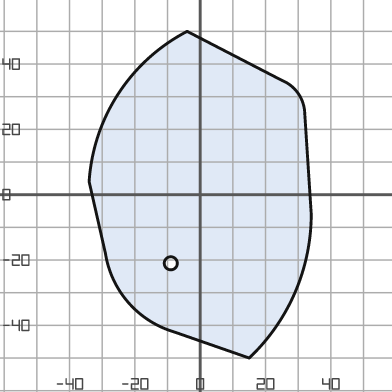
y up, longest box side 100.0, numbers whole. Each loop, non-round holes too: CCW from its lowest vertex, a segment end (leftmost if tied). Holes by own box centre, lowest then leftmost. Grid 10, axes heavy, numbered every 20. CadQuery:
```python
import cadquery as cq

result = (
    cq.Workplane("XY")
    .moveTo(15.0, -50.0)
    .threePointArc((29.0, -30.0), (34.0, -6.0))
    .lineTo(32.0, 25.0)
    .threePointArc((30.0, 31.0), (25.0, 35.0))
    .lineTo(-4.0, 50.0)
    .threePointArc((-25.0, 31.0), (-34.0, 4.0))
    .lineTo(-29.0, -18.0)
    .threePointArc((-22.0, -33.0), (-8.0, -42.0))
    .close()
    .moveTo(-9.0, -21.0)
    .circle(2.0)
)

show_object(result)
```